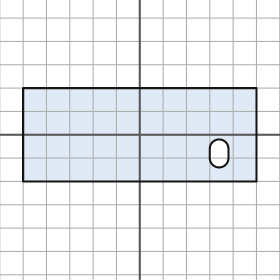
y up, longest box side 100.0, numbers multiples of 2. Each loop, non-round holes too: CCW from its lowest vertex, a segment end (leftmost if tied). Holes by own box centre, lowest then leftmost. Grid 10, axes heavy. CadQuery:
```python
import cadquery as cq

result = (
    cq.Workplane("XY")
    .moveTo(-50.0, -20.0)
    .lineTo(50.0, -20.0)
    .lineTo(50.0, 20.0)
    .lineTo(-50.0, 20.0)
    .close()
    .moveTo(30.0, -10.0)
    .threePointArc((34.0, -14.0), (38.0, -10.0))
    .lineTo(38.0, -6.0)
    .threePointArc((34.0, -2.0), (30.0, -6.0))
    .close()
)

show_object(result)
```